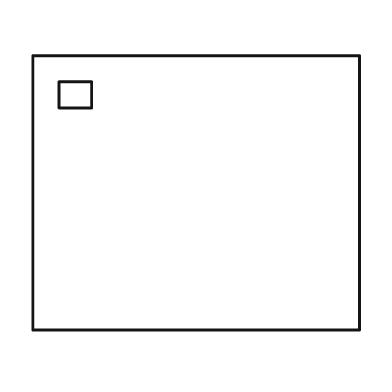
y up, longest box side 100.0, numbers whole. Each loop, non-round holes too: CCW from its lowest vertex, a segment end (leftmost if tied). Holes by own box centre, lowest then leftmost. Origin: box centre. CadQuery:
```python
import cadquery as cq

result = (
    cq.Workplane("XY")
    .moveTo(-50.0, -42.0)
    .lineTo(50.0, -42.0)
    .lineTo(50.0, 42.0)
    .lineTo(-50.0, 42.0)
    .close()
    .moveTo(-42.0, 26.0)
    .lineTo(-32.0, 26.0)
    .lineTo(-32.0, 34.0)
    .lineTo(-42.0, 34.0)
    .close()
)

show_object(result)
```